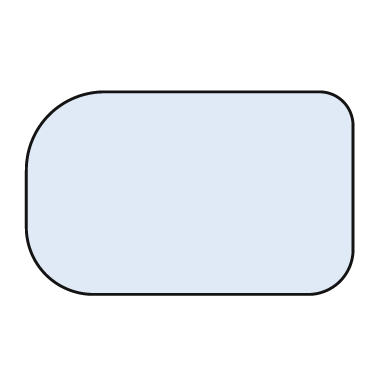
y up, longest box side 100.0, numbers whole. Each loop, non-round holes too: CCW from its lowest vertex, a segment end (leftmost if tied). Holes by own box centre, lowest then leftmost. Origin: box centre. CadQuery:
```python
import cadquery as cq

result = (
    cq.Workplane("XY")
    .moveTo(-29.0, -31.0)
    .lineTo(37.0, -31.0)
    .threePointArc((46.0, -27.0), (50.0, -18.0))
    .lineTo(50.0, 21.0)
    .threePointArc((47.0, 28.0), (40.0, 31.0))
    .lineTo(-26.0, 31.0)
    .threePointArc((-43.0, 24.0), (-50.0, 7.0))
    .lineTo(-50.0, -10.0)
    .threePointArc((-44.0, -25.0), (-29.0, -31.0))
    .close()
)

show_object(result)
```